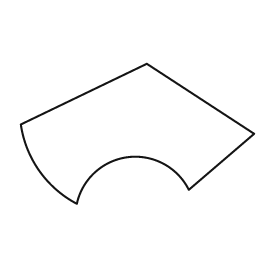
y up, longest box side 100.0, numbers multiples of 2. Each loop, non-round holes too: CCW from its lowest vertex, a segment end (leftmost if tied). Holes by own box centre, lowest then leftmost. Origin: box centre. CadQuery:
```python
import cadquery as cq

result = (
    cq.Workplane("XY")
    .moveTo(-26.0, -30.0)
    .threePointArc((-4.0, -10.0), (22.0, -24.0))
    .lineTo(50.0, 0.0)
    .lineTo(4.0, 30.0)
    .lineTo(-50.0, 4.0)
    .threePointArc((-42.0, -16.0), (-26.0, -30.0))
    .close()
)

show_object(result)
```